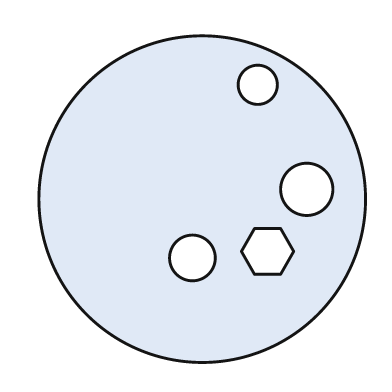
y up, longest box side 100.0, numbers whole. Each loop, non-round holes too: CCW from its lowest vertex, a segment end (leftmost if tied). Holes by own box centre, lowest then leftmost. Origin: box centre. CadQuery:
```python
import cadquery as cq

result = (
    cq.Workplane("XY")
    .moveTo(0.0, 0.0)
    .circle(50.0)
    .moveTo(-3.0, -18.0)
    .circle(7.0)
    .moveTo(16.0, -23.0)
    .lineTo(24.0, -23.0)
    .lineTo(28.0, -16.0)
    .lineTo(24.0, -9.0)
    .lineTo(16.0, -9.0)
    .lineTo(12.0, -16.0)
    .close()
    .moveTo(32.0, 3.0)
    .circle(8.0)
    .moveTo(17.0, 35.0)
    .circle(6.0)
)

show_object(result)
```